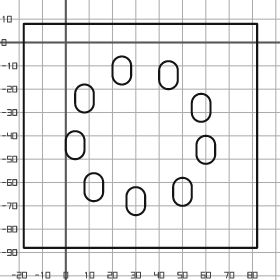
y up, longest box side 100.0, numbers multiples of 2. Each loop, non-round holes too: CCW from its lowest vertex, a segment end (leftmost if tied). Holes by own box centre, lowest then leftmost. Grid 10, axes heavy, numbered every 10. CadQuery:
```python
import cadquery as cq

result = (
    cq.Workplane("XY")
    .moveTo(-18.0, -88.0)
    .lineTo(82.0, -88.0)
    .lineTo(82.0, 8.0)
    .lineTo(-18.0, 8.0)
    .close()
    .moveTo(26.0, -70.0)
    .threePointArc((30.0, -74.0), (34.0, -70.0))
    .lineTo(34.0, -66.0)
    .threePointArc((30.0, -62.0), (26.0, -66.0))
    .close()
    .moveTo(46.0, -66.0)
    .threePointArc((50.0, -70.0), (54.0, -66.0))
    .lineTo(54.0, -62.0)
    .threePointArc((50.0, -58.0), (46.0, -62.0))
    .close()
    .moveTo(8.0, -64.0)
    .threePointArc((12.0, -68.0), (16.0, -64.0))
    .lineTo(16.0, -60.0)
    .threePointArc((12.0, -56.0), (8.0, -60.0))
    .close()
    .moveTo(56.0, -48.0)
    .threePointArc((60.0, -52.0), (64.0, -48.0))
    .lineTo(64.0, -44.0)
    .threePointArc((60.0, -40.0), (56.0, -44.0))
    .close()
    .moveTo(0.0, -46.0)
    .threePointArc((4.0, -50.0), (8.0, -46.0))
    .lineTo(8.0, -42.0)
    .threePointArc((4.0, -38.0), (0.0, -42.0))
    .close()
    .moveTo(54.0, -30.0)
    .threePointArc((58.0, -34.0), (62.0, -30.0))
    .lineTo(62.0, -26.0)
    .threePointArc((58.0, -22.0), (54.0, -26.0))
    .close()
    .moveTo(4.0, -26.0)
    .threePointArc((8.0, -30.0), (12.0, -26.0))
    .lineTo(12.0, -22.0)
    .threePointArc((8.0, -18.0), (4.0, -22.0))
    .close()
    .moveTo(40.0, -16.0)
    .threePointArc((44.0, -20.0), (48.0, -16.0))
    .lineTo(48.0, -12.0)
    .threePointArc((44.0, -8.0), (40.0, -12.0))
    .close()
    .moveTo(20.0, -14.0)
    .threePointArc((24.0, -18.0), (28.0, -14.0))
    .lineTo(28.0, -10.0)
    .threePointArc((24.0, -6.0), (20.0, -10.0))
    .close()
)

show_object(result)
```